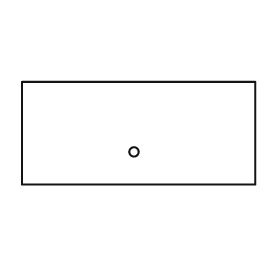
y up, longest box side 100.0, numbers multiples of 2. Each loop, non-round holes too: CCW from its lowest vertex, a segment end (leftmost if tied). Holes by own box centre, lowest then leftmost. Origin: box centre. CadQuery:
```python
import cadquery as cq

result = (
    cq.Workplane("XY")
    .moveTo(-50.0, -22.0)
    .lineTo(50.0, -22.0)
    .lineTo(50.0, 22.0)
    .lineTo(-50.0, 22.0)
    .close()
    .moveTo(-2.0, -8.0)
    .circle(2.0)
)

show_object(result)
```